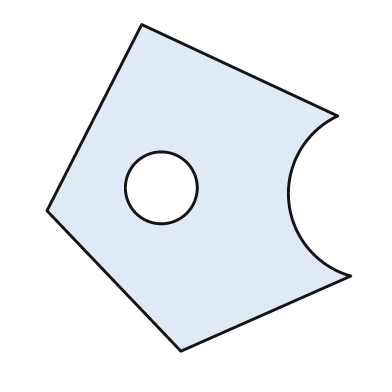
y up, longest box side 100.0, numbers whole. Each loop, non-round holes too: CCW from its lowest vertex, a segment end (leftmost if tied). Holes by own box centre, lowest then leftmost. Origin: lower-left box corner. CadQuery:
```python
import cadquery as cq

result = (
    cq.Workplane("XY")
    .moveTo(41.0, 0.0)
    .lineTo(93.0, 23.0)
    .threePointArc((74.0, 46.0), (89.0, 72.0))
    .lineTo(29.0, 100.0)
    .lineTo(0.0, 43.0)
    .close()
    .moveTo(35.0, 50.0)
    .circle(11.0)
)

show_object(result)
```